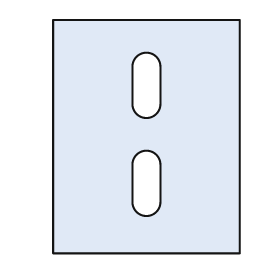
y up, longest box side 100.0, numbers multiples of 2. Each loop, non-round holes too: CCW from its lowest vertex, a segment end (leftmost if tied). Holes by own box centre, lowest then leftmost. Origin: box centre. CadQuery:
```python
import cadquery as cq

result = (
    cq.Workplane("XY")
    .moveTo(-40.0, -50.0)
    .lineTo(40.0, -50.0)
    .lineTo(40.0, 50.0)
    .lineTo(-40.0, 50.0)
    .close()
    .moveTo(-6.0, -28.0)
    .threePointArc((0.0, -34.0), (6.0, -28.0))
    .lineTo(6.0, -12.0)
    .threePointArc((0.0, -6.0), (-6.0, -12.0))
    .close()
    .moveTo(-6.0, 14.0)
    .threePointArc((0.0, 8.0), (6.0, 14.0))
    .lineTo(6.0, 30.0)
    .threePointArc((0.0, 36.0), (-6.0, 30.0))
    .close()
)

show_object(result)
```